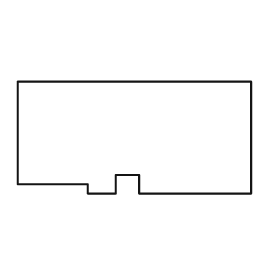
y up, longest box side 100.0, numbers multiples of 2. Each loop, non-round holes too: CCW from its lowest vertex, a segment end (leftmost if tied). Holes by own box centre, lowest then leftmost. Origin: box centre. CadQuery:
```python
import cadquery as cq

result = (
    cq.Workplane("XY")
    .moveTo(-20.0, -24.0)
    .lineTo(-8.0, -24.0)
    .lineTo(-8.0, -16.0)
    .lineTo(2.0, -16.0)
    .lineTo(2.0, -24.0)
    .lineTo(50.0, -24.0)
    .lineTo(50.0, 24.0)
    .lineTo(-50.0, 24.0)
    .lineTo(-50.0, -20.0)
    .lineTo(-20.0, -20.0)
    .close()
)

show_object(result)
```